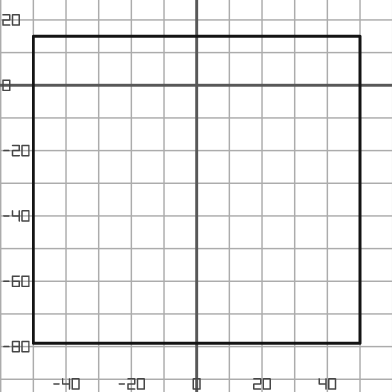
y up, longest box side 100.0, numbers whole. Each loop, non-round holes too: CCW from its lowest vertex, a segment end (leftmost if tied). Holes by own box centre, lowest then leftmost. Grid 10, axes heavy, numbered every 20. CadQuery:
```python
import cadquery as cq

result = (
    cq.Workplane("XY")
    .moveTo(-50.0, -79.0)
    .lineTo(50.0, -79.0)
    .lineTo(50.0, 15.0)
    .lineTo(-50.0, 15.0)
    .close()
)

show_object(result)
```